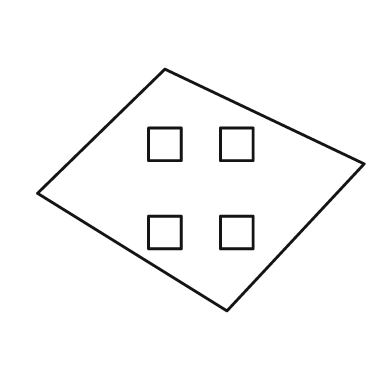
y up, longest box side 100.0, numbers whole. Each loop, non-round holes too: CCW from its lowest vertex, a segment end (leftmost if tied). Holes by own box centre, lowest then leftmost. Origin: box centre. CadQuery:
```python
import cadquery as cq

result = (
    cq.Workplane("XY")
    .moveTo(8.0, -37.0)
    .lineTo(50.0, 8.0)
    .lineTo(-11.0, 37.0)
    .lineTo(-50.0, -1.0)
    .close()
    .moveTo(-16.0, -18.0)
    .lineTo(-6.0, -18.0)
    .lineTo(-6.0, -8.0)
    .lineTo(-16.0, -8.0)
    .close()
    .moveTo(6.0, -18.0)
    .lineTo(16.0, -18.0)
    .lineTo(16.0, -8.0)
    .lineTo(6.0, -8.0)
    .close()
    .moveTo(-16.0, 9.0)
    .lineTo(-6.0, 9.0)
    .lineTo(-6.0, 19.0)
    .lineTo(-16.0, 19.0)
    .close()
    .moveTo(6.0, 9.0)
    .lineTo(16.0, 9.0)
    .lineTo(16.0, 19.0)
    .lineTo(6.0, 19.0)
    .close()
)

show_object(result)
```